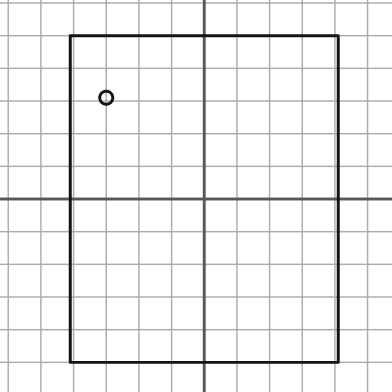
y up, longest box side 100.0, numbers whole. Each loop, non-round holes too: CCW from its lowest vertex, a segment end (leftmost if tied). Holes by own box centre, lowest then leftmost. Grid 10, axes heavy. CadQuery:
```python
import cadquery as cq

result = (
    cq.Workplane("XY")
    .moveTo(-41.0, -50.0)
    .lineTo(41.0, -50.0)
    .lineTo(41.0, 50.0)
    .lineTo(-41.0, 50.0)
    .close()
    .moveTo(-30.0, 31.0)
    .circle(2.0)
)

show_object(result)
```